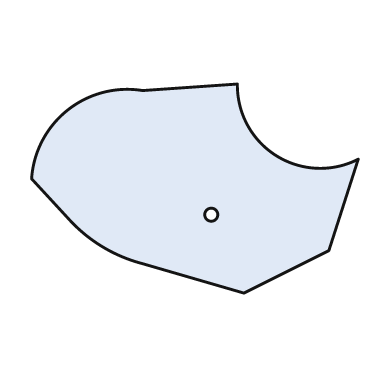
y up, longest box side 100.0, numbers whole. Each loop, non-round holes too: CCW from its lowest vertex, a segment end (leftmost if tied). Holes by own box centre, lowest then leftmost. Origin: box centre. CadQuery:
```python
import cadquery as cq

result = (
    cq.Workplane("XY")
    .moveTo(15.0, -32.0)
    .lineTo(41.0, -19.0)
    .lineTo(50.0, 9.0)
    .threePointArc((25.0, 10.0), (13.0, 32.0))
    .lineTo(-16.0, 30.0)
    .threePointArc((-39.0, 24.0), (-50.0, 3.0))
    .lineTo(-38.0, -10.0)
    .threePointArc((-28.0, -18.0), (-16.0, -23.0))
    .close()
    .moveTo(5.0, -8.0)
    .circle(2.0)
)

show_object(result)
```